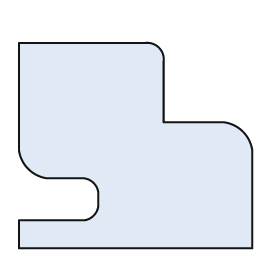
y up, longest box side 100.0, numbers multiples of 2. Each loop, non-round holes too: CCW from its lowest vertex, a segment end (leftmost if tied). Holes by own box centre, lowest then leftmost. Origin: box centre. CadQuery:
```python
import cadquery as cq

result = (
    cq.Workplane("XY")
    .moveTo(-50.0, -44.0)
    .lineTo(50.0, -44.0)
    .lineTo(50.0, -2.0)
    .threePointArc((46.0, 6.0), (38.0, 10.0))
    .lineTo(12.0, 10.0)
    .lineTo(12.0, 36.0)
    .threePointArc((10.0, 42.0), (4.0, 44.0))
    .lineTo(-50.0, 44.0)
    .lineTo(-50.0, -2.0)
    .threePointArc((-46.0, -10.0), (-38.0, -14.0))
    .lineTo(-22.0, -14.0)
    .threePointArc((-18.0, -16.0), (-16.0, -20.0))
    .lineTo(-16.0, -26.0)
    .threePointArc((-18.0, -30.0), (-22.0, -32.0))
    .lineTo(-50.0, -32.0)
    .close()
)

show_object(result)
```